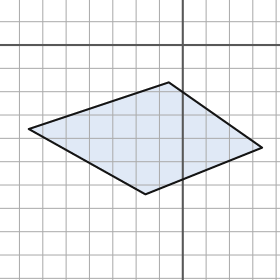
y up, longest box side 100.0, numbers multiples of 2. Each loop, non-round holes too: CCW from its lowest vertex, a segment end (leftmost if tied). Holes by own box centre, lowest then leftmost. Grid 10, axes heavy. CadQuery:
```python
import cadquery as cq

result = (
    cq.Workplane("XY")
    .moveTo(-16.0, -64.0)
    .lineTo(34.0, -44.0)
    .lineTo(-6.0, -16.0)
    .lineTo(-66.0, -36.0)
    .close()
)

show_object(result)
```